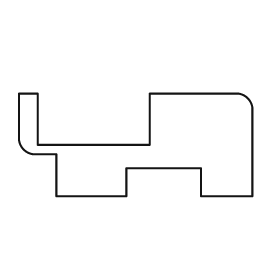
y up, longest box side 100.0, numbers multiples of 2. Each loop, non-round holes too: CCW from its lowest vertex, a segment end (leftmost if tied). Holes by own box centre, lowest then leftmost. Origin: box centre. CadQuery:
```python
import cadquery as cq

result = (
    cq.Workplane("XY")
    .moveTo(-34.0, -22.0)
    .lineTo(-4.0, -22.0)
    .lineTo(-4.0, -10.0)
    .lineTo(28.0, -10.0)
    .lineTo(28.0, -22.0)
    .lineTo(50.0, -22.0)
    .lineTo(50.0, 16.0)
    .threePointArc((48.0, 20.0), (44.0, 22.0))
    .lineTo(6.0, 22.0)
    .lineTo(6.0, 0.0)
    .lineTo(-42.0, 0.0)
    .lineTo(-42.0, 22.0)
    .lineTo(-50.0, 22.0)
    .lineTo(-50.0, 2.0)
    .threePointArc((-48.0, -2.0), (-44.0, -4.0))
    .lineTo(-34.0, -4.0)
    .close()
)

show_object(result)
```